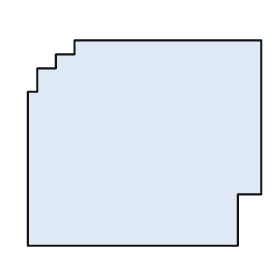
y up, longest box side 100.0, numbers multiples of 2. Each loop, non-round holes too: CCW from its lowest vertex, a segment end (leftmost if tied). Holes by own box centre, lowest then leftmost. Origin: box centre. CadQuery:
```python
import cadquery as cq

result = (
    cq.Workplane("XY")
    .moveTo(-50.0, -44.0)
    .lineTo(40.0, -44.0)
    .lineTo(40.0, -22.0)
    .lineTo(50.0, -22.0)
    .lineTo(50.0, 44.0)
    .lineTo(-30.0, 44.0)
    .lineTo(-30.0, 38.0)
    .lineTo(-38.0, 38.0)
    .lineTo(-38.0, 32.0)
    .lineTo(-46.0, 32.0)
    .lineTo(-46.0, 22.0)
    .lineTo(-50.0, 22.0)
    .close()
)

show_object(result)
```